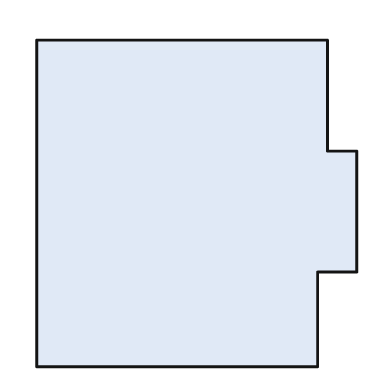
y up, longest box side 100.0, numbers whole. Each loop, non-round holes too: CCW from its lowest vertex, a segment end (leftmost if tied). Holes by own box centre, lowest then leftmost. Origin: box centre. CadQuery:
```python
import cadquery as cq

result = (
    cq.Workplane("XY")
    .moveTo(-49.0, -50.0)
    .lineTo(37.0, -50.0)
    .lineTo(37.0, -21.0)
    .lineTo(49.0, -21.0)
    .lineTo(49.0, 16.0)
    .lineTo(40.0, 16.0)
    .lineTo(40.0, 50.0)
    .lineTo(-49.0, 50.0)
    .close()
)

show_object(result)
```